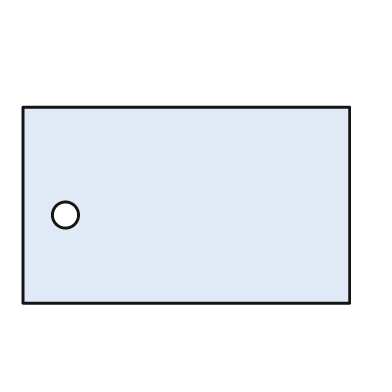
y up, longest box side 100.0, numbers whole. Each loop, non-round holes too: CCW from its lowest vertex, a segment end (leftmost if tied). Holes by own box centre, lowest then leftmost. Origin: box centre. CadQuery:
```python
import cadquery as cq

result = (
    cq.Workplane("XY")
    .moveTo(-50.0, -30.0)
    .lineTo(50.0, -30.0)
    .lineTo(50.0, 30.0)
    .lineTo(-50.0, 30.0)
    .close()
    .moveTo(-37.0, -3.0)
    .circle(4.0)
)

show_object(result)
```